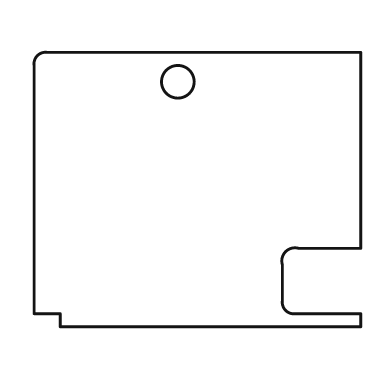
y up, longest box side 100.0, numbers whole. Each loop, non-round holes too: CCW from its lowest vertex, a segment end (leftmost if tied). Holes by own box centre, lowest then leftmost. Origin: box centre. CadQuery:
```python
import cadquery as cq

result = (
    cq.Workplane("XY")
    .moveTo(-42.0, -42.0)
    .lineTo(50.0, -42.0)
    .lineTo(50.0, -38.0)
    .lineTo(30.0, -38.0)
    .threePointArc((27.0, -37.0), (26.0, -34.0))
    .lineTo(26.0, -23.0)
    .threePointArc((27.0, -19.0), (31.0, -18.0))
    .lineTo(50.0, -18.0)
    .lineTo(50.0, 42.0)
    .lineTo(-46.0, 42.0)
    .threePointArc((-49.0, 41.0), (-50.0, 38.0))
    .lineTo(-50.0, -38.0)
    .lineTo(-42.0, -38.0)
    .close()
    .moveTo(-6.0, 33.0)
    .circle(5.0)
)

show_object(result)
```